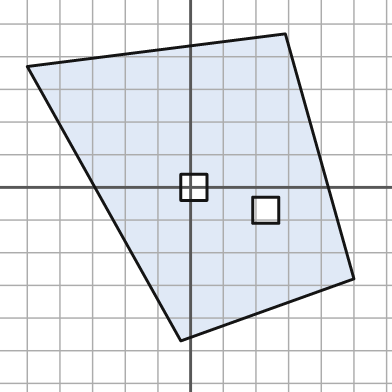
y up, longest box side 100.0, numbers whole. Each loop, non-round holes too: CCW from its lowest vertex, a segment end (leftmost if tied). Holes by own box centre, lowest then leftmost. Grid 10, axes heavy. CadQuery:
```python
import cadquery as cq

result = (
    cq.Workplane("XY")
    .moveTo(-3.0, -47.0)
    .lineTo(50.0, -28.0)
    .lineTo(29.0, 47.0)
    .lineTo(-50.0, 37.0)
    .close()
    .moveTo(19.0, -11.0)
    .lineTo(27.0, -11.0)
    .lineTo(27.0, -3.0)
    .lineTo(19.0, -3.0)
    .close()
    .moveTo(-3.0, -4.0)
    .lineTo(5.0, -4.0)
    .lineTo(5.0, 4.0)
    .lineTo(-3.0, 4.0)
    .close()
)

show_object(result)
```